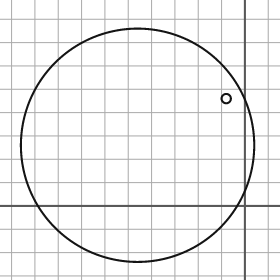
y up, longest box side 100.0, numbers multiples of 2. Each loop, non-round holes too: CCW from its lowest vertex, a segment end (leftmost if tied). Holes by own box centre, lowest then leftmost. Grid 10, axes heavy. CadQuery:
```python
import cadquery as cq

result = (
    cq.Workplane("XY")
    .moveTo(-46.0, 26.0)
    .circle(50.0)
    .moveTo(-8.0, 46.0)
    .circle(2.0)
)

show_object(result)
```